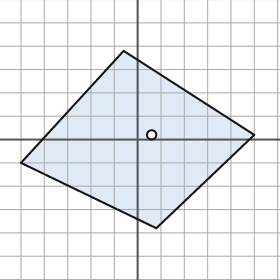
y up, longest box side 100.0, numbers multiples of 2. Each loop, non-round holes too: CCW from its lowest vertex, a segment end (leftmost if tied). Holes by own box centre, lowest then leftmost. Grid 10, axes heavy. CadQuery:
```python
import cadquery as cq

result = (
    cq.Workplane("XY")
    .moveTo(8.0, -38.0)
    .lineTo(50.0, 2.0)
    .lineTo(-6.0, 38.0)
    .lineTo(-50.0, -10.0)
    .close()
    .moveTo(6.0, 2.0)
    .circle(2.0)
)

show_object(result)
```